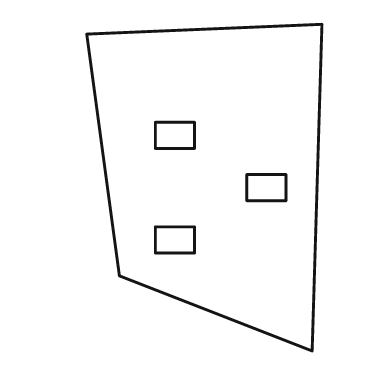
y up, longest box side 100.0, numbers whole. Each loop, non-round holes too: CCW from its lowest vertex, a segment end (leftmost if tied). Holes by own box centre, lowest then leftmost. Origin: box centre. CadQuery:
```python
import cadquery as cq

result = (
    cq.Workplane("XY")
    .moveTo(33.0, -50.0)
    .lineTo(36.0, 50.0)
    .lineTo(-36.0, 47.0)
    .lineTo(-26.0, -27.0)
    .close()
    .moveTo(-15.0, -20.0)
    .lineTo(-3.0, -20.0)
    .lineTo(-3.0, -12.0)
    .lineTo(-15.0, -12.0)
    .close()
    .moveTo(13.0, -4.0)
    .lineTo(25.0, -4.0)
    .lineTo(25.0, 4.0)
    .lineTo(13.0, 4.0)
    .close()
    .moveTo(-15.0, 12.0)
    .lineTo(-3.0, 12.0)
    .lineTo(-3.0, 20.0)
    .lineTo(-15.0, 20.0)
    .close()
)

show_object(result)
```